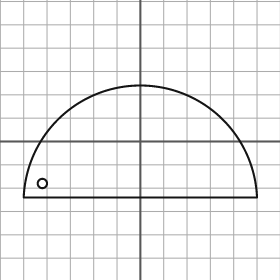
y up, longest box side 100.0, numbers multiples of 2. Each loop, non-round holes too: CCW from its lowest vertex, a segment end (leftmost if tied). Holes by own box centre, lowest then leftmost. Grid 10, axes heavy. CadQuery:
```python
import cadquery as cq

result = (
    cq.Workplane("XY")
    .moveTo(-50.0, -24.0)
    .lineTo(50.0, -24.0)
    .threePointArc((0.0, 24.0), (-50.0, -24.0))
    .close()
    .moveTo(-42.0, -18.0)
    .circle(2.0)
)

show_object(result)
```